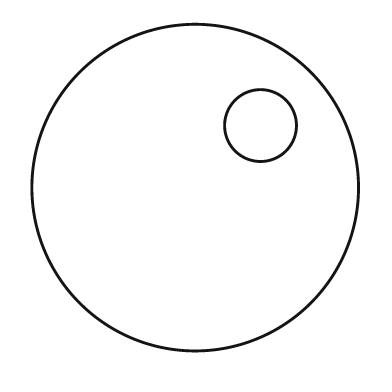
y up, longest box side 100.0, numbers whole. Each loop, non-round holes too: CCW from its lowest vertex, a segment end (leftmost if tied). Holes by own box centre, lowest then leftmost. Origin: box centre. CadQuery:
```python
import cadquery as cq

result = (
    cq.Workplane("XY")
    .moveTo(0.0, 0.0)
    .circle(50.0)
    .moveTo(20.0, 19.0)
    .circle(11.0)
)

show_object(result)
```